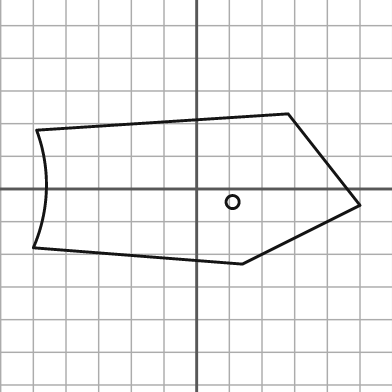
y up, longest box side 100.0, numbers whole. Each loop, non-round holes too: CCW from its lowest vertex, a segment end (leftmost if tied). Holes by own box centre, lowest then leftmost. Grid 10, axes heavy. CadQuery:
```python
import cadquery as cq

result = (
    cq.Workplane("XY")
    .moveTo(14.0, -23.0)
    .lineTo(50.0, -5.0)
    .lineTo(28.0, 23.0)
    .lineTo(-49.0, 18.0)
    .threePointArc((-46.0, 0.0), (-50.0, -18.0))
    .close()
    .moveTo(11.0, -4.0)
    .circle(2.0)
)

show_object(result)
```